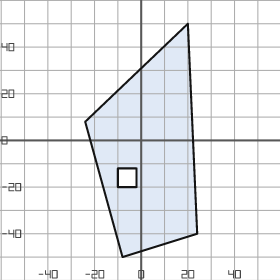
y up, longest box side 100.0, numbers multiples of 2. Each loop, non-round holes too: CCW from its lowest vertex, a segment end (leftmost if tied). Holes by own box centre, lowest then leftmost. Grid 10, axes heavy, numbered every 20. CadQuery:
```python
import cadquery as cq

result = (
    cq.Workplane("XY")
    .moveTo(-8.0, -50.0)
    .lineTo(24.0, -40.0)
    .lineTo(20.0, 50.0)
    .lineTo(-24.0, 8.0)
    .close()
    .moveTo(-10.0, -20.0)
    .lineTo(-2.0, -20.0)
    .lineTo(-2.0, -12.0)
    .lineTo(-10.0, -12.0)
    .close()
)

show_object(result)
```